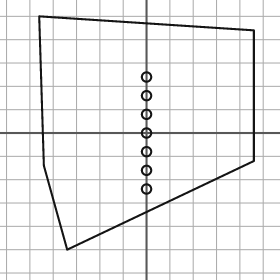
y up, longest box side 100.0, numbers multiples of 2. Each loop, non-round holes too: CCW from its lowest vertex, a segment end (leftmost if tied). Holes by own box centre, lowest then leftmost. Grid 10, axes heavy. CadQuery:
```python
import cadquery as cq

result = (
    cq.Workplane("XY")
    .moveTo(-34.0, -50.0)
    .lineTo(46.0, -12.0)
    .lineTo(46.0, 44.0)
    .lineTo(-46.0, 50.0)
    .lineTo(-44.0, -14.0)
    .close()
    .moveTo(0.0, -24.0)
    .circle(2.0)
    .moveTo(0.0, -16.0)
    .circle(2.0)
    .moveTo(0.0, -8.0)
    .circle(2.0)
    .moveTo(0.0, 0.0)
    .circle(2.0)
    .moveTo(0.0, 8.0)
    .circle(2.0)
    .moveTo(0.0, 16.0)
    .circle(2.0)
    .moveTo(0.0, 24.0)
    .circle(2.0)
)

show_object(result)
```